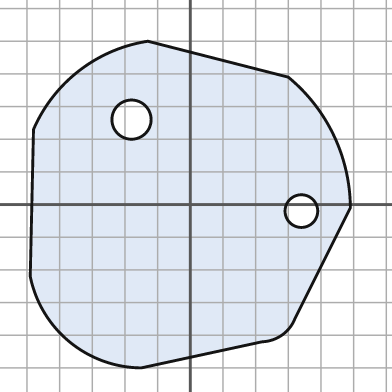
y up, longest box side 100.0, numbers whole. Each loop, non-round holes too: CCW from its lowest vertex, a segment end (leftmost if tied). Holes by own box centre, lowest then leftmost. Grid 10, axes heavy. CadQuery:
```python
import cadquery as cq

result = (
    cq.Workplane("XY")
    .moveTo(-15.0, -50.0)
    .lineTo(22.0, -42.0)
    .threePointArc((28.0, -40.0), (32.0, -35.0))
    .lineTo(49.0, -1.0)
    .threePointArc((44.0, 21.0), (30.0, 39.0))
    .lineTo(-13.0, 50.0)
    .threePointArc((-34.0, 41.0), (-48.0, 23.0))
    .lineTo(-49.0, -22.0)
    .threePointArc((-37.0, -42.0), (-15.0, -50.0))
    .close()
    .moveTo(34.0, -2.0)
    .circle(5.0)
    .moveTo(-18.0, 26.0)
    .circle(6.0)
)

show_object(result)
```